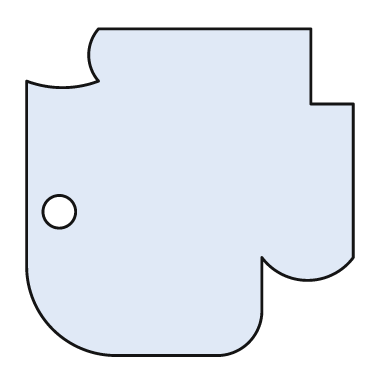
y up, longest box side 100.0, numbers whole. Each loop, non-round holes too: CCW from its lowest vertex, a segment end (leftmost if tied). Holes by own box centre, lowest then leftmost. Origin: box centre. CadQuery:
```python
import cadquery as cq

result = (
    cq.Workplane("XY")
    .moveTo(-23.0, -50.0)
    .lineTo(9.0, -50.0)
    .threePointArc((18.0, -46.0), (22.0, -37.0))
    .lineTo(22.0, -20.0)
    .threePointArc((36.0, -27.0), (50.0, -20.0))
    .lineTo(50.0, 27.0)
    .lineTo(37.0, 27.0)
    .lineTo(37.0, 50.0)
    .lineTo(-28.0, 50.0)
    .threePointArc((-31.0, 42.0), (-28.0, 34.0))
    .threePointArc((-39.0, 32.0), (-50.0, 34.0))
    .lineTo(-50.0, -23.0)
    .threePointArc((-42.0, -42.0), (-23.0, -50.0))
    .close()
    .moveTo(-40.0, -6.0)
    .circle(5.0)
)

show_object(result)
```